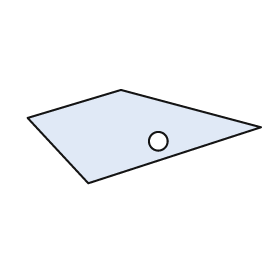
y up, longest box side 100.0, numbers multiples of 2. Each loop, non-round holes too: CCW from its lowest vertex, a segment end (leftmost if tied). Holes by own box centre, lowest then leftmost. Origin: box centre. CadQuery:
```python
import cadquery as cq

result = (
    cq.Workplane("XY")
    .moveTo(-24.0, -20.0)
    .lineTo(50.0, 4.0)
    .lineTo(-10.0, 20.0)
    .lineTo(-50.0, 8.0)
    .close()
    .moveTo(6.0, -2.0)
    .circle(4.0)
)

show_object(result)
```